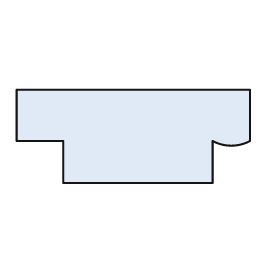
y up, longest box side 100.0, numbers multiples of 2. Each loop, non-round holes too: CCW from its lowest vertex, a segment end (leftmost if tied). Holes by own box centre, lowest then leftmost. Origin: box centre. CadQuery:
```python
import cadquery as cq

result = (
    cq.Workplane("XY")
    .moveTo(-30.0, -20.0)
    .lineTo(34.0, -20.0)
    .lineTo(34.0, -2.0)
    .threePointArc((42.0, -4.0), (50.0, -2.0))
    .lineTo(50.0, 20.0)
    .lineTo(-50.0, 20.0)
    .lineTo(-50.0, -2.0)
    .lineTo(-30.0, -2.0)
    .close()
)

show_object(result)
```